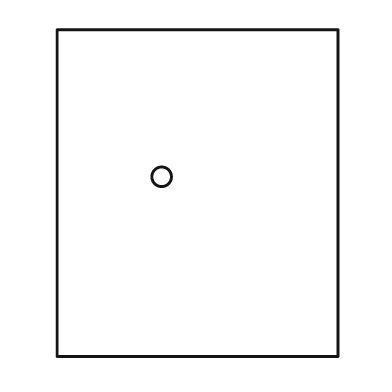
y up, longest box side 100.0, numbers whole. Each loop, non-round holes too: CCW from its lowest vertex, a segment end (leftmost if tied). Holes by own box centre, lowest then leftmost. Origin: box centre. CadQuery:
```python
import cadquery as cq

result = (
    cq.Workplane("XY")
    .moveTo(-43.0, -50.0)
    .lineTo(43.0, -50.0)
    .lineTo(43.0, 50.0)
    .lineTo(-43.0, 50.0)
    .close()
    .moveTo(-11.0, 5.0)
    .circle(3.0)
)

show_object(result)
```